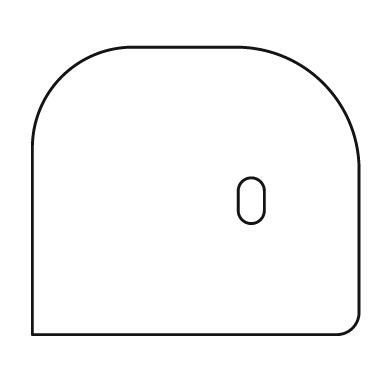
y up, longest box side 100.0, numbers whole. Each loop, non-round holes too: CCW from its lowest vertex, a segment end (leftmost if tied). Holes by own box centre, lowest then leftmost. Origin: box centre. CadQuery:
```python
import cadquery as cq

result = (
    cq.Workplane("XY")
    .moveTo(-50.0, -44.0)
    .lineTo(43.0, -44.0)
    .threePointArc((48.0, -42.0), (50.0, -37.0))
    .lineTo(50.0, 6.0)
    .threePointArc((39.0, 33.0), (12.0, 44.0))
    .lineTo(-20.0, 44.0)
    .threePointArc((-41.0, 35.0), (-50.0, 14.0))
    .close()
    .moveTo(13.0, -6.0)
    .threePointArc((17.0, -10.0), (21.0, -6.0))
    .lineTo(21.0, 0.0)
    .threePointArc((17.0, 4.0), (13.0, 0.0))
    .close()
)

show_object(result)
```